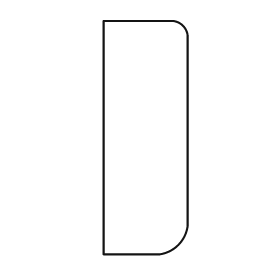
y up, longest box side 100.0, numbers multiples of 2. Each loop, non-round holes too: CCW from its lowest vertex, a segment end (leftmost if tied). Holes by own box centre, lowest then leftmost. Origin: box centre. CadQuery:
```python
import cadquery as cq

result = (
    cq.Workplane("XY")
    .moveTo(-18.0, -50.0)
    .lineTo(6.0, -50.0)
    .threePointArc((14.0, -46.0), (18.0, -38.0))
    .lineTo(18.0, 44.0)
    .threePointArc((16.0, 48.0), (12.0, 50.0))
    .lineTo(-18.0, 50.0)
    .close()
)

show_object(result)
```